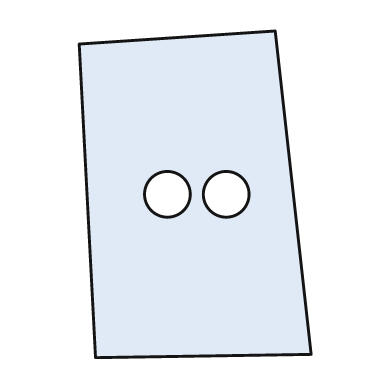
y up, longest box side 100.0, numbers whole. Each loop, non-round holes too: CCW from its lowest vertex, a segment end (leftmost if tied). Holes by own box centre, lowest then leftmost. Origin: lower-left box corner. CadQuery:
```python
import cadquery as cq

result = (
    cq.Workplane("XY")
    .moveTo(5.0, 0.0)
    .lineTo(71.0, 1.0)
    .lineTo(60.0, 100.0)
    .lineTo(0.0, 96.0)
    .close()
    .moveTo(27.0, 50.0)
    .circle(7.0)
    .moveTo(45.0, 50.0)
    .circle(7.0)
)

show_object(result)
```